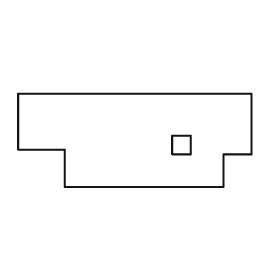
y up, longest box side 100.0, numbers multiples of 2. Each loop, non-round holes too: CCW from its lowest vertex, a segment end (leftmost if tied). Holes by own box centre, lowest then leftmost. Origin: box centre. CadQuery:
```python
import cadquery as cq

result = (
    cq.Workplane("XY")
    .moveTo(-30.0, -20.0)
    .lineTo(38.0, -20.0)
    .lineTo(38.0, -6.0)
    .lineTo(50.0, -6.0)
    .lineTo(50.0, 20.0)
    .lineTo(-50.0, 20.0)
    .lineTo(-50.0, -4.0)
    .lineTo(-30.0, -4.0)
    .close()
    .moveTo(16.0, -6.0)
    .lineTo(24.0, -6.0)
    .lineTo(24.0, 2.0)
    .lineTo(16.0, 2.0)
    .close()
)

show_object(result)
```